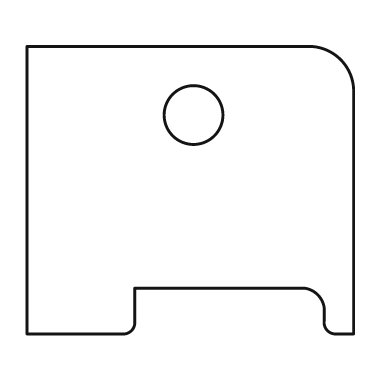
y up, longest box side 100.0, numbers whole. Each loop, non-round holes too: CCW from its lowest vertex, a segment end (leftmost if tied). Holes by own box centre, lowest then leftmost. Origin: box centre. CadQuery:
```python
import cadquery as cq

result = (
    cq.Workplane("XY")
    .moveTo(-50.0, -44.0)
    .lineTo(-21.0, -44.0)
    .threePointArc((-18.0, -43.0), (-17.0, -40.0))
    .lineTo(-17.0, -30.0)
    .lineTo(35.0, -30.0)
    .threePointArc((39.0, -32.0), (41.0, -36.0))
    .lineTo(41.0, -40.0)
    .threePointArc((42.0, -43.0), (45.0, -44.0))
    .lineTo(50.0, -44.0)
    .lineTo(50.0, 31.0)
    .threePointArc((46.0, 40.0), (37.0, 44.0))
    .lineTo(-50.0, 44.0)
    .close()
    .moveTo(1.0, 23.0)
    .circle(9.0)
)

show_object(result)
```